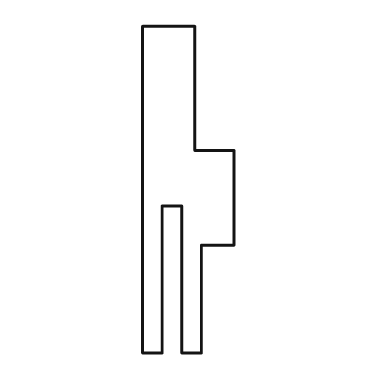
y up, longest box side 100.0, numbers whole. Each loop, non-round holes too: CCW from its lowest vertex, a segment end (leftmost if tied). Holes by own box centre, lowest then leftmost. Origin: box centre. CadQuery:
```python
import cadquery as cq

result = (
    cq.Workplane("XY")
    .moveTo(-14.0, -50.0)
    .lineTo(-8.0, -50.0)
    .lineTo(-8.0, -5.0)
    .lineTo(-2.0, -5.0)
    .lineTo(-2.0, -50.0)
    .lineTo(4.0, -50.0)
    .lineTo(4.0, -17.0)
    .lineTo(14.0, -17.0)
    .lineTo(14.0, 12.0)
    .lineTo(2.0, 12.0)
    .lineTo(2.0, 50.0)
    .lineTo(-14.0, 50.0)
    .close()
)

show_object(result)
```